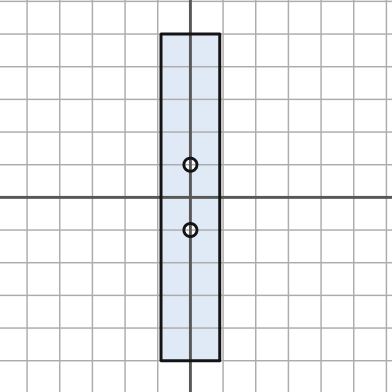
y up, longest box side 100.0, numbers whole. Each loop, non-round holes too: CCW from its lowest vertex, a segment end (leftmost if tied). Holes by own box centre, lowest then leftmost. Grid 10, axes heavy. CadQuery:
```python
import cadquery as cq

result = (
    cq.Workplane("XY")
    .moveTo(-9.0, -50.0)
    .lineTo(9.0, -50.0)
    .lineTo(9.0, 50.0)
    .lineTo(-9.0, 50.0)
    .close()
    .moveTo(0.0, -10.0)
    .circle(2.0)
    .moveTo(0.0, 10.0)
    .circle(2.0)
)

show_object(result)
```